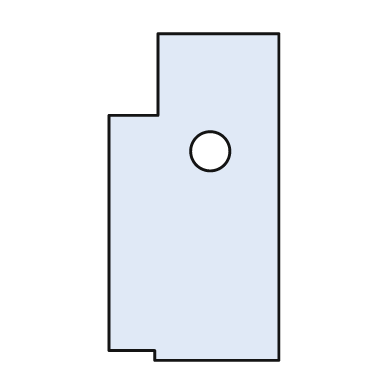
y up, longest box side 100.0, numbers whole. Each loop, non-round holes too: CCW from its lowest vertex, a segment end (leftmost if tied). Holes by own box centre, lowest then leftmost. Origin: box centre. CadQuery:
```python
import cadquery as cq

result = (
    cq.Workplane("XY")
    .moveTo(-12.0, -50.0)
    .lineTo(26.0, -50.0)
    .lineTo(26.0, 50.0)
    .lineTo(-11.0, 50.0)
    .lineTo(-11.0, 25.0)
    .lineTo(-26.0, 25.0)
    .lineTo(-26.0, -47.0)
    .lineTo(-12.0, -47.0)
    .close()
    .moveTo(5.0, 14.0)
    .circle(6.0)
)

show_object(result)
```